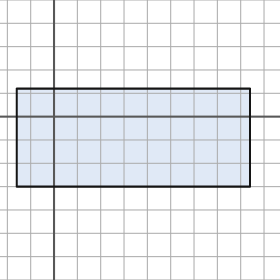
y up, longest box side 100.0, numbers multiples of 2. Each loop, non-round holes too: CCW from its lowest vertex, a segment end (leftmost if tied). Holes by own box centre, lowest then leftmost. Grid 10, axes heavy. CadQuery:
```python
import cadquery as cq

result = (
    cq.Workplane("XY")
    .moveTo(-16.0, -30.0)
    .lineTo(84.0, -30.0)
    .lineTo(84.0, 12.0)
    .lineTo(-16.0, 12.0)
    .close()
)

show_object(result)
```